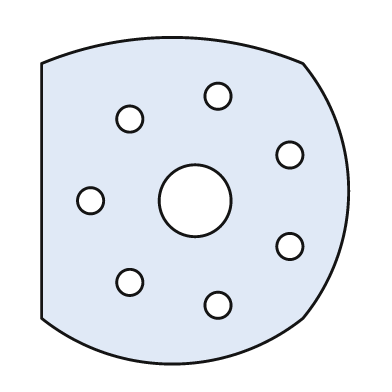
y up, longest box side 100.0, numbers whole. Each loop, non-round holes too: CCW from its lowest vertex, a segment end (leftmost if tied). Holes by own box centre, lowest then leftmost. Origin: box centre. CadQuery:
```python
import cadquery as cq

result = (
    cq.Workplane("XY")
    .moveTo(-47.0, -36.0)
    .threePointArc((-7.0, -50.0), (33.0, -36.0))
    .threePointArc((47.0, 3.0), (33.0, 42.0))
    .threePointArc((-7.0, 50.0), (-47.0, 42.0))
    .close()
    .moveTo(7.0, -32.0)
    .circle(4.0)
    .moveTo(-20.0, -25.0)
    .circle(4.0)
    .moveTo(29.0, -14.0)
    .circle(4.0)
    .moveTo(-32.0, 0.0)
    .circle(4.0)
    .moveTo(0.0, 0.0)
    .circle(11.0)
    .moveTo(29.0, 14.0)
    .circle(4.0)
    .moveTo(-20.0, 25.0)
    .circle(4.0)
    .moveTo(7.0, 32.0)
    .circle(4.0)
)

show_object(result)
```